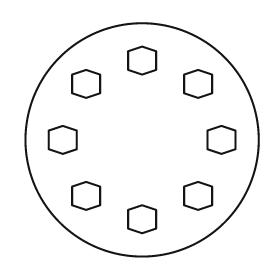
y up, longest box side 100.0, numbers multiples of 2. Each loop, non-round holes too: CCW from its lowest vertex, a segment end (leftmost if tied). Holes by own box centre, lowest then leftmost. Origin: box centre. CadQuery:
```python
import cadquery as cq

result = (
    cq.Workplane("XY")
    .moveTo(0.0, 0.0)
    .circle(50.0)
    .moveTo(0.0, -40.0)
    .lineTo(6.0, -38.0)
    .lineTo(6.0, -30.0)
    .lineTo(0.0, -28.0)
    .lineTo(-6.0, -30.0)
    .lineTo(-6.0, -38.0)
    .close()
    .moveTo(-24.0, -30.0)
    .lineTo(-18.0, -28.0)
    .lineTo(-18.0, -20.0)
    .lineTo(-24.0, -18.0)
    .lineTo(-30.0, -20.0)
    .lineTo(-30.0, -28.0)
    .close()
    .moveTo(24.0, -30.0)
    .lineTo(30.0, -28.0)
    .lineTo(30.0, -20.0)
    .lineTo(24.0, -18.0)
    .lineTo(18.0, -20.0)
    .lineTo(18.0, -28.0)
    .close()
    .moveTo(-34.0, -6.0)
    .lineTo(-28.0, -4.0)
    .lineTo(-28.0, 4.0)
    .lineTo(-34.0, 6.0)
    .lineTo(-40.0, 4.0)
    .lineTo(-40.0, -4.0)
    .close()
    .moveTo(34.0, -6.0)
    .lineTo(40.0, -4.0)
    .lineTo(40.0, 4.0)
    .lineTo(34.0, 6.0)
    .lineTo(28.0, 4.0)
    .lineTo(28.0, -4.0)
    .close()
    .moveTo(-24.0, 18.0)
    .lineTo(-18.0, 20.0)
    .lineTo(-18.0, 28.0)
    .lineTo(-24.0, 30.0)
    .lineTo(-30.0, 28.0)
    .lineTo(-30.0, 20.0)
    .close()
    .moveTo(24.0, 18.0)
    .lineTo(30.0, 20.0)
    .lineTo(30.0, 28.0)
    .lineTo(24.0, 30.0)
    .lineTo(18.0, 28.0)
    .lineTo(18.0, 20.0)
    .close()
    .moveTo(0.0, 28.0)
    .lineTo(6.0, 30.0)
    .lineTo(6.0, 38.0)
    .lineTo(0.0, 40.0)
    .lineTo(-6.0, 38.0)
    .lineTo(-6.0, 30.0)
    .close()
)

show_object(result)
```